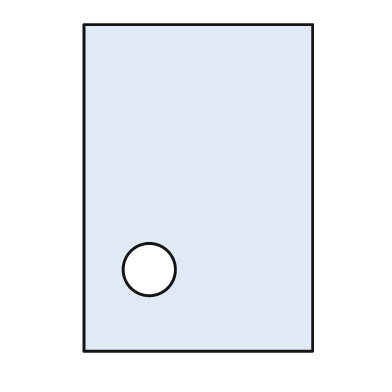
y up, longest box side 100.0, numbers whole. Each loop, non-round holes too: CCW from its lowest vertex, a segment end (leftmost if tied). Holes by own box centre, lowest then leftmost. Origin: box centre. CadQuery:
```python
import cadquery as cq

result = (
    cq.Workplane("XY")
    .moveTo(-35.0, -50.0)
    .lineTo(35.0, -50.0)
    .lineTo(35.0, 50.0)
    .lineTo(-35.0, 50.0)
    .close()
    .moveTo(-15.0, -25.0)
    .circle(8.0)
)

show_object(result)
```